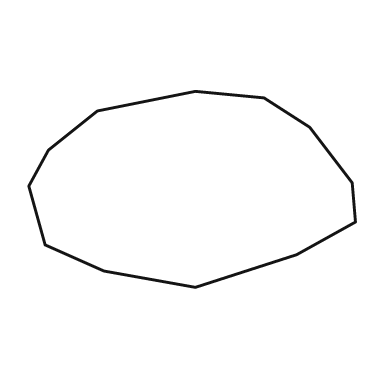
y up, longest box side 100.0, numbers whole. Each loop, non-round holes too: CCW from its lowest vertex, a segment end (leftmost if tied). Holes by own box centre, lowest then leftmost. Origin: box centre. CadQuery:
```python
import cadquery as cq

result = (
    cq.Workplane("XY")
    .moveTo(1.0, -30.0)
    .lineTo(32.0, -20.0)
    .lineTo(50.0, -10.0)
    .lineTo(49.0, 2.0)
    .lineTo(36.0, 19.0)
    .lineTo(22.0, 28.0)
    .lineTo(1.0, 30.0)
    .lineTo(-29.0, 24.0)
    .lineTo(-44.0, 12.0)
    .lineTo(-50.0, 1.0)
    .lineTo(-45.0, -17.0)
    .lineTo(-27.0, -25.0)
    .close()
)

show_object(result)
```